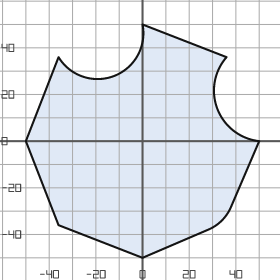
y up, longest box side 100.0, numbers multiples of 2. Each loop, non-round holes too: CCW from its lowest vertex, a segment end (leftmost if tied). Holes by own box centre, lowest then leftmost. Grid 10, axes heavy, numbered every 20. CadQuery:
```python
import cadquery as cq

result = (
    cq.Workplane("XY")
    .moveTo(0.0, -50.0)
    .lineTo(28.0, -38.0)
    .threePointArc((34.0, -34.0), (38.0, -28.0))
    .lineTo(50.0, 0.0)
    .threePointArc((32.0, 14.0), (36.0, 36.0))
    .lineTo(0.0, 50.0)
    .threePointArc((-12.0, 28.0), (-36.0, 36.0))
    .lineTo(-50.0, 0.0)
    .lineTo(-36.0, -36.0)
    .close()
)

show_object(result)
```